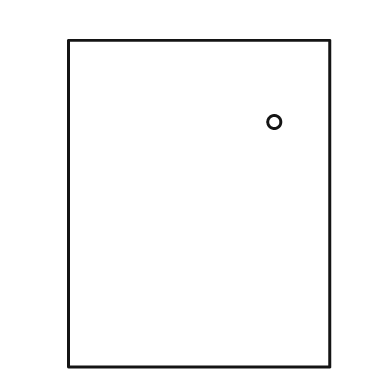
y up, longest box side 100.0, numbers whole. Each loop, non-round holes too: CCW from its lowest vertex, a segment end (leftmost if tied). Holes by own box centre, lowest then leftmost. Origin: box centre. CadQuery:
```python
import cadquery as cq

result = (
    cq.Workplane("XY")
    .moveTo(-40.0, -50.0)
    .lineTo(40.0, -50.0)
    .lineTo(40.0, 50.0)
    .lineTo(-40.0, 50.0)
    .close()
    .moveTo(23.0, 25.0)
    .circle(2.0)
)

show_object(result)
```